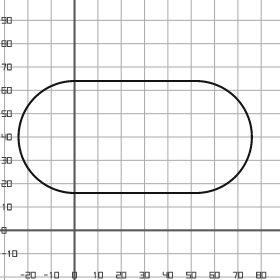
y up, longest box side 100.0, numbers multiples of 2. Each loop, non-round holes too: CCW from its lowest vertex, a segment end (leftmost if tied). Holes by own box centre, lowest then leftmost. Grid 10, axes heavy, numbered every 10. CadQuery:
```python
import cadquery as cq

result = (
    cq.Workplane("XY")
    .moveTo(0.0, 16.0)
    .lineTo(52.0, 16.0)
    .threePointArc((76.0, 40.0), (52.0, 64.0))
    .lineTo(0.0, 64.0)
    .threePointArc((-24.0, 40.0), (0.0, 16.0))
    .close()
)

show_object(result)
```